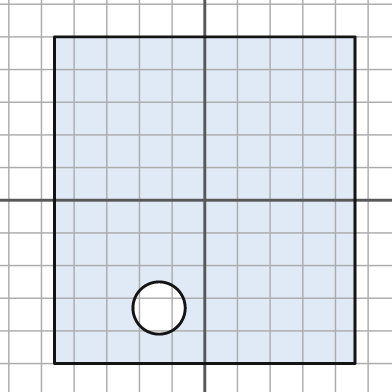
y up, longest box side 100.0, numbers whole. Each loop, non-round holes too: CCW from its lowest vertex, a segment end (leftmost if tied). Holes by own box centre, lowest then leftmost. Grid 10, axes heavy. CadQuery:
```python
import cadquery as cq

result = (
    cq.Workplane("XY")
    .moveTo(-46.0, -50.0)
    .lineTo(46.0, -50.0)
    .lineTo(46.0, 50.0)
    .lineTo(-46.0, 50.0)
    .close()
    .moveTo(-14.0, -33.0)
    .circle(8.0)
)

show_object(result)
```